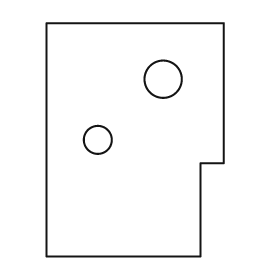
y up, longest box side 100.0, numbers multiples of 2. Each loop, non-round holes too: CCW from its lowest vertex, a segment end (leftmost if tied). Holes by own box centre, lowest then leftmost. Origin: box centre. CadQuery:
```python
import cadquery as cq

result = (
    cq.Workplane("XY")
    .moveTo(-38.0, -50.0)
    .lineTo(28.0, -50.0)
    .lineTo(28.0, -10.0)
    .lineTo(38.0, -10.0)
    .lineTo(38.0, 50.0)
    .lineTo(-38.0, 50.0)
    .close()
    .moveTo(-16.0, 0.0)
    .circle(6.0)
    .moveTo(12.0, 26.0)
    .circle(8.0)
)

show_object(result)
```